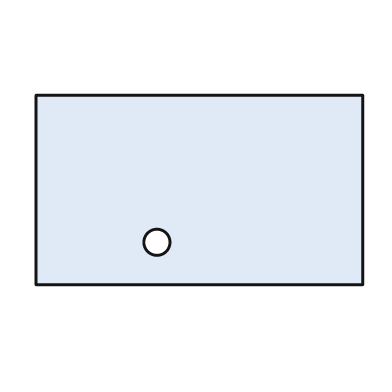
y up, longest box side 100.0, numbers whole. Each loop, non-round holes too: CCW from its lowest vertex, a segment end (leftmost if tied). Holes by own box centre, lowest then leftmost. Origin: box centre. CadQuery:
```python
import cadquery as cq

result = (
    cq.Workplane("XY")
    .moveTo(-50.0, -29.0)
    .lineTo(50.0, -29.0)
    .lineTo(50.0, 29.0)
    .lineTo(-50.0, 29.0)
    .close()
    .moveTo(-13.0, -16.0)
    .circle(4.0)
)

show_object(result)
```